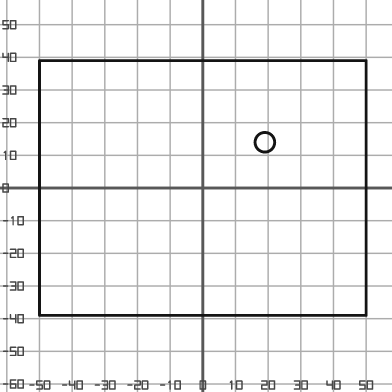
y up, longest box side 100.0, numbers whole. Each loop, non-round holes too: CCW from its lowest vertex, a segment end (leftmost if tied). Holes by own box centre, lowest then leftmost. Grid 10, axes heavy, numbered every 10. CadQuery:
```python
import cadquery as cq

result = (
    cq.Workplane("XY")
    .moveTo(-50.0, -39.0)
    .lineTo(50.0, -39.0)
    .lineTo(50.0, 39.0)
    .lineTo(-50.0, 39.0)
    .close()
    .moveTo(19.0, 14.0)
    .circle(3.0)
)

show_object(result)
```